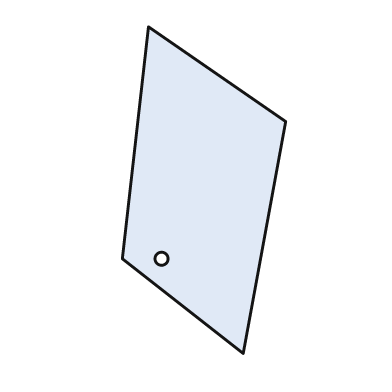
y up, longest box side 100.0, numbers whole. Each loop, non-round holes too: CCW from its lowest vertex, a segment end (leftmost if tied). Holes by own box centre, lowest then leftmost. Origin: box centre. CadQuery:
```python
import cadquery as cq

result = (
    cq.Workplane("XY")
    .moveTo(12.0, -50.0)
    .lineTo(25.0, 21.0)
    .lineTo(-17.0, 50.0)
    .lineTo(-25.0, -21.0)
    .close()
    .moveTo(-13.0, -21.0)
    .circle(2.0)
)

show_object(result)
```